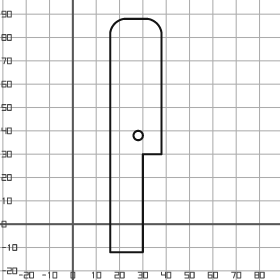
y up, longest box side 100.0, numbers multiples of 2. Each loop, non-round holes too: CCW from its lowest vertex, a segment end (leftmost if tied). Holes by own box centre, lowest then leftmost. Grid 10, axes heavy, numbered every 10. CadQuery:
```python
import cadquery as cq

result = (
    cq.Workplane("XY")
    .moveTo(16.0, -12.0)
    .lineTo(30.0, -12.0)
    .lineTo(30.0, 30.0)
    .lineTo(38.0, 30.0)
    .lineTo(38.0, 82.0)
    .threePointArc((36.0, 86.0), (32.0, 88.0))
    .lineTo(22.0, 88.0)
    .threePointArc((18.0, 86.0), (16.0, 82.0))
    .close()
    .moveTo(28.0, 38.0)
    .circle(2.0)
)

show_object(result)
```